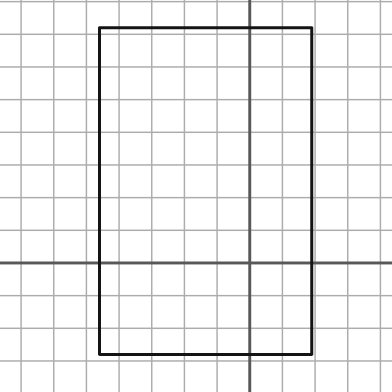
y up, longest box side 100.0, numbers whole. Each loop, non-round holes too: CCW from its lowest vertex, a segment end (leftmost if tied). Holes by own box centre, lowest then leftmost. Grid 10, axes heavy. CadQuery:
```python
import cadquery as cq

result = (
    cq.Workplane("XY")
    .moveTo(-46.0, -28.0)
    .lineTo(19.0, -28.0)
    .lineTo(19.0, 72.0)
    .lineTo(-46.0, 72.0)
    .close()
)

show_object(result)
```